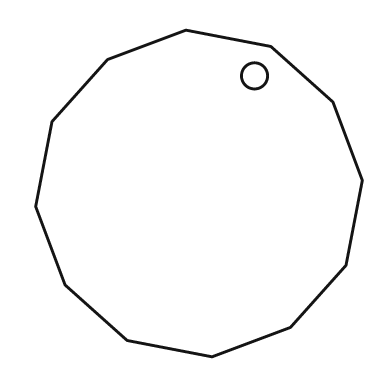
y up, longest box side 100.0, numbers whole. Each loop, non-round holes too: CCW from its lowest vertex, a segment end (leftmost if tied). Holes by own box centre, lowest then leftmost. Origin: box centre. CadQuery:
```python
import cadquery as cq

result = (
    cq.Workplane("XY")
    .moveTo(4.0, -50.0)
    .lineTo(28.0, -41.0)
    .lineTo(45.0, -22.0)
    .lineTo(50.0, 4.0)
    .lineTo(41.0, 28.0)
    .lineTo(22.0, 45.0)
    .lineTo(-4.0, 50.0)
    .lineTo(-28.0, 41.0)
    .lineTo(-45.0, 22.0)
    .lineTo(-50.0, -4.0)
    .lineTo(-41.0, -28.0)
    .lineTo(-22.0, -45.0)
    .close()
    .moveTo(17.0, 36.0)
    .circle(4.0)
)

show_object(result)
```